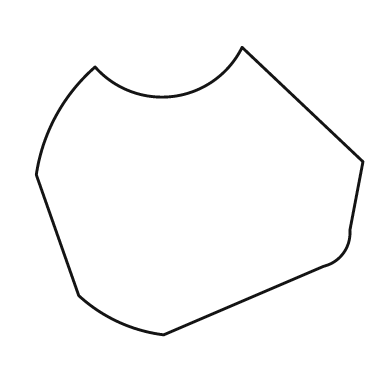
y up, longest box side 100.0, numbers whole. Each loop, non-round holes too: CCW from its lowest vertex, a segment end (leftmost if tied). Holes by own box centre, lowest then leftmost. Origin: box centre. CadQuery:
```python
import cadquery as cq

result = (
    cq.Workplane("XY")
    .moveTo(-11.0, -44.0)
    .lineTo(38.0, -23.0)
    .threePointArc((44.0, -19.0), (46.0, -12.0))
    .lineTo(50.0, 9.0)
    .lineTo(13.0, 44.0)
    .threePointArc((-8.0, 29.0), (-32.0, 38.0))
    .threePointArc((-44.0, 23.0), (-50.0, 5.0))
    .lineTo(-37.0, -32.0)
    .threePointArc((-25.0, -40.0), (-11.0, -44.0))
    .close()
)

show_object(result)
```